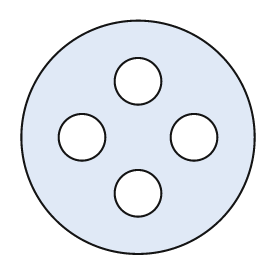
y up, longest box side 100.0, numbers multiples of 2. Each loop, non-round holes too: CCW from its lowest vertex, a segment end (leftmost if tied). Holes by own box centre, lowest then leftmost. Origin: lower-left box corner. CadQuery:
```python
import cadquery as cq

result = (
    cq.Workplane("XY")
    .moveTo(50.0, 50.0)
    .circle(50.0)
    .moveTo(50.0, 26.0)
    .circle(10.0)
    .moveTo(26.0, 50.0)
    .circle(10.0)
    .moveTo(74.0, 50.0)
    .circle(10.0)
    .moveTo(50.0, 74.0)
    .circle(10.0)
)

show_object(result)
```